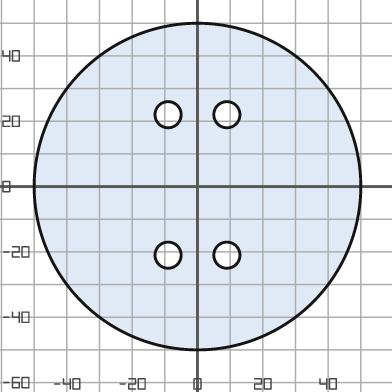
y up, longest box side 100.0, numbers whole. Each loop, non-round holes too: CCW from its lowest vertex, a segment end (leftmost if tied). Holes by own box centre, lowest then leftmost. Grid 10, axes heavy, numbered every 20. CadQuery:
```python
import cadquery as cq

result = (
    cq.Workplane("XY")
    .moveTo(0.0, 0.0)
    .circle(50.0)
    .moveTo(-9.0, -21.0)
    .circle(4.0)
    .moveTo(9.0, -21.0)
    .circle(4.0)
    .moveTo(-9.0, 22.0)
    .circle(4.0)
    .moveTo(9.0, 22.0)
    .circle(4.0)
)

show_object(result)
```